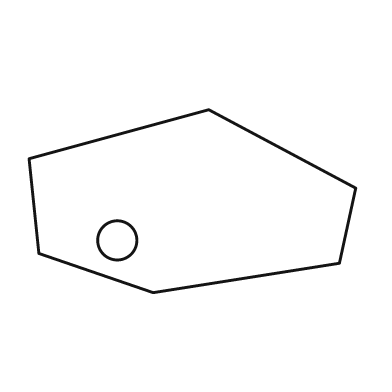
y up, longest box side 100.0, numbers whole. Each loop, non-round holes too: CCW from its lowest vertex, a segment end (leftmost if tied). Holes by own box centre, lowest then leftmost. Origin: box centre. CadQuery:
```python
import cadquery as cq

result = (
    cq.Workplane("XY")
    .moveTo(-12.0, -28.0)
    .lineTo(45.0, -19.0)
    .lineTo(50.0, 4.0)
    .lineTo(5.0, 28.0)
    .lineTo(-50.0, 13.0)
    .lineTo(-47.0, -16.0)
    .close()
    .moveTo(-23.0, -12.0)
    .circle(6.0)
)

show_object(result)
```